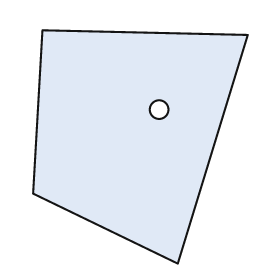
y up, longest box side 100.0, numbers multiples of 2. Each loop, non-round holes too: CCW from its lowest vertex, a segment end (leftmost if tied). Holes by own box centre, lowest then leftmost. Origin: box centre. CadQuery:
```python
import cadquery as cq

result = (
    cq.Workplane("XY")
    .moveTo(16.0, -50.0)
    .lineTo(46.0, 48.0)
    .lineTo(-42.0, 50.0)
    .lineTo(-46.0, -20.0)
    .close()
    .moveTo(8.0, 16.0)
    .circle(4.0)
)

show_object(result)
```